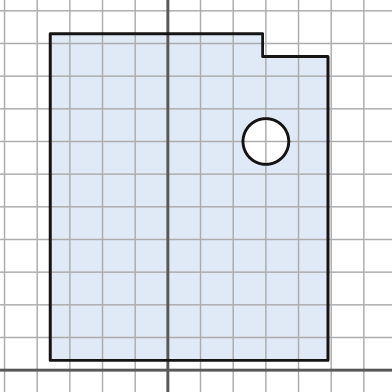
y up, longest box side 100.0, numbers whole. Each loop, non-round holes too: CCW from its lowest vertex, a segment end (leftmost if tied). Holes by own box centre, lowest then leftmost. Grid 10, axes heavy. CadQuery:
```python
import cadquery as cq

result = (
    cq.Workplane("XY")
    .moveTo(-36.0, 3.0)
    .lineTo(49.0, 3.0)
    .lineTo(49.0, 96.0)
    .lineTo(29.0, 96.0)
    .lineTo(29.0, 103.0)
    .lineTo(-36.0, 103.0)
    .close()
    .moveTo(30.0, 70.0)
    .circle(7.0)
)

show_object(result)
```